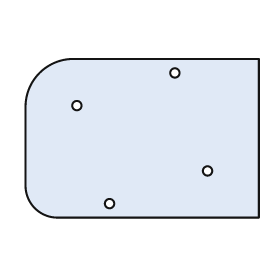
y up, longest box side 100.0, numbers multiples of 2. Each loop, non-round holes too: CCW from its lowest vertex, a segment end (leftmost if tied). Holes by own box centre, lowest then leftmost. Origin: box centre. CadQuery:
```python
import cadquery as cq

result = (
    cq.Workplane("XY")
    .moveTo(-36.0, -34.0)
    .lineTo(50.0, -34.0)
    .lineTo(50.0, 34.0)
    .lineTo(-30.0, 34.0)
    .threePointArc((-44.0, 28.0), (-50.0, 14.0))
    .lineTo(-50.0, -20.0)
    .threePointArc((-46.0, -30.0), (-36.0, -34.0))
    .close()
    .moveTo(-14.0, -28.0)
    .circle(2.0)
    .moveTo(28.0, -14.0)
    .circle(2.0)
    .moveTo(-28.0, 14.0)
    .circle(2.0)
    .moveTo(14.0, 28.0)
    .circle(2.0)
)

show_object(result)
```